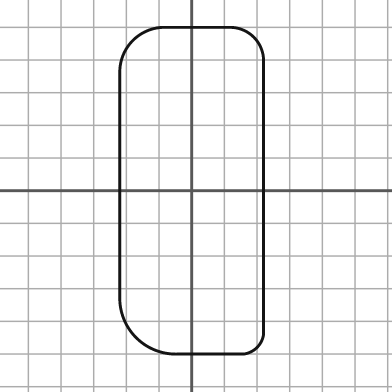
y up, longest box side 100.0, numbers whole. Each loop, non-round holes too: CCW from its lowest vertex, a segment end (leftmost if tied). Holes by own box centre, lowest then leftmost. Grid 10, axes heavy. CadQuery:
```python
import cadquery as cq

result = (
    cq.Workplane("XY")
    .moveTo(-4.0, -50.0)
    .lineTo(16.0, -50.0)
    .threePointArc((20.0, -48.0), (22.0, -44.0))
    .lineTo(22.0, 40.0)
    .threePointArc((19.0, 47.0), (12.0, 50.0))
    .lineTo(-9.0, 50.0)
    .threePointArc((-18.0, 46.0), (-22.0, 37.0))
    .lineTo(-22.0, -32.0)
    .threePointArc((-17.0, -45.0), (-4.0, -50.0))
    .close()
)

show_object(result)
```